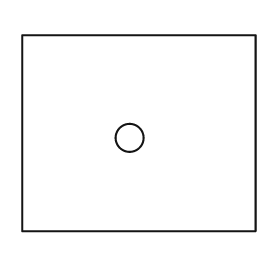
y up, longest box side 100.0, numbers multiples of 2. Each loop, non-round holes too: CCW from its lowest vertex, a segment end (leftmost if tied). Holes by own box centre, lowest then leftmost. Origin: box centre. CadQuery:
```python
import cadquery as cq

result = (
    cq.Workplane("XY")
    .moveTo(-50.0, -42.0)
    .lineTo(50.0, -42.0)
    .lineTo(50.0, 42.0)
    .lineTo(-50.0, 42.0)
    .close()
    .moveTo(-4.0, -2.0)
    .circle(6.0)
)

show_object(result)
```